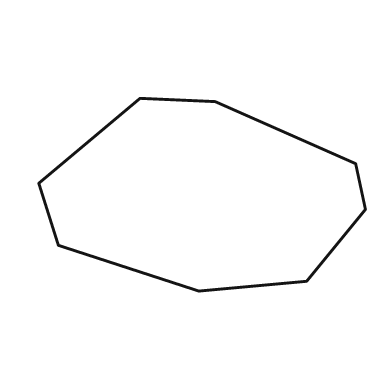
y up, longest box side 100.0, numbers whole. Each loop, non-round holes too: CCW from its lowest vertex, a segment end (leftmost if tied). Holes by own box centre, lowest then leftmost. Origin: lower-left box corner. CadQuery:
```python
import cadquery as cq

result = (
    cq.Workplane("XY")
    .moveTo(49.0, 0.0)
    .lineTo(82.0, 3.0)
    .lineTo(100.0, 25.0)
    .lineTo(97.0, 39.0)
    .lineTo(54.0, 58.0)
    .lineTo(31.0, 59.0)
    .lineTo(0.0, 33.0)
    .lineTo(6.0, 14.0)
    .close()
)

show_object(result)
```